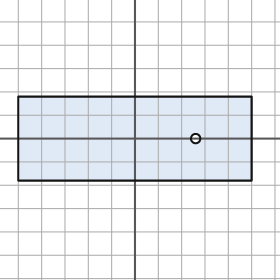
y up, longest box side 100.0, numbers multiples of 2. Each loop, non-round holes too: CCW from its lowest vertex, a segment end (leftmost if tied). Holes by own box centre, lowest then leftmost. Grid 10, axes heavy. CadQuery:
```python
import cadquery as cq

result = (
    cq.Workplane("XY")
    .moveTo(-50.0, -18.0)
    .lineTo(50.0, -18.0)
    .lineTo(50.0, 18.0)
    .lineTo(-50.0, 18.0)
    .close()
    .moveTo(26.0, 0.0)
    .circle(2.0)
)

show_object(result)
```